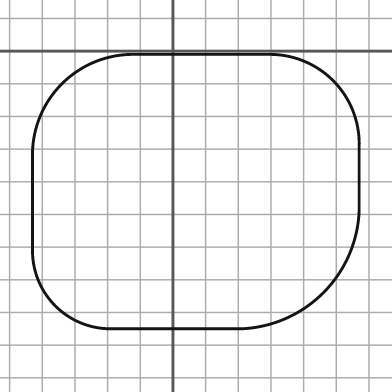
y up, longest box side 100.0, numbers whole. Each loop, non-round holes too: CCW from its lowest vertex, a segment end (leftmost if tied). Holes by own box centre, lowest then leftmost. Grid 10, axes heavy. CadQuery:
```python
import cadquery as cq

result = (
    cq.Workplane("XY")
    .moveTo(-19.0, -85.0)
    .lineTo(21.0, -85.0)
    .threePointArc((46.0, -74.0), (57.0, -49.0))
    .lineTo(57.0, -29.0)
    .threePointArc((49.0, -9.0), (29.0, -1.0))
    .lineTo(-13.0, -1.0)
    .threePointArc((-34.0, -10.0), (-43.0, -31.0))
    .lineTo(-43.0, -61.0)
    .threePointArc((-36.0, -78.0), (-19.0, -85.0))
    .close()
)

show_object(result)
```